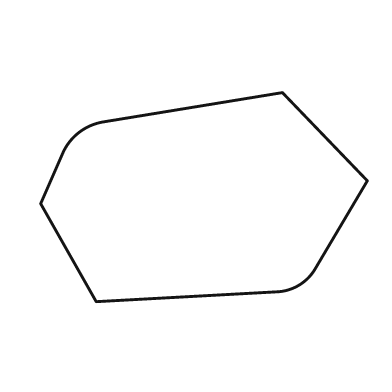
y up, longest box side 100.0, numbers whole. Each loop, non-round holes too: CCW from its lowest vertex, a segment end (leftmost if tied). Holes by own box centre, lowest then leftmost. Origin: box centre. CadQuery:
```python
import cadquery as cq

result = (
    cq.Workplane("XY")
    .moveTo(-33.0, -32.0)
    .lineTo(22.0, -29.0)
    .threePointArc((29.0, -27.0), (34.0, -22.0))
    .lineTo(50.0, 5.0)
    .lineTo(24.0, 32.0)
    .lineTo(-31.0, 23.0)
    .threePointArc((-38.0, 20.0), (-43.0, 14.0))
    .lineTo(-50.0, -2.0)
    .close()
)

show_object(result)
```